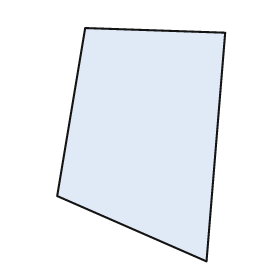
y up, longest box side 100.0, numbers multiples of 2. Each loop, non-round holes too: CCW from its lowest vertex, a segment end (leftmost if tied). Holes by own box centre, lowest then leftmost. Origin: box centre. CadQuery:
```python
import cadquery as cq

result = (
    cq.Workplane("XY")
    .moveTo(28.0, -50.0)
    .lineTo(36.0, 48.0)
    .lineTo(-24.0, 50.0)
    .lineTo(-36.0, -22.0)
    .close()
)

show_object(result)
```